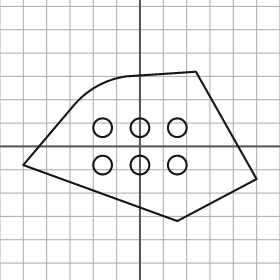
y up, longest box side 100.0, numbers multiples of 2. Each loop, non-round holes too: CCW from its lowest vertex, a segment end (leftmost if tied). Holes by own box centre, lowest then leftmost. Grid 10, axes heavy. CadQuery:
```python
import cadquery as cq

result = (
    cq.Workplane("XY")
    .moveTo(16.0, -32.0)
    .lineTo(50.0, -14.0)
    .lineTo(24.0, 32.0)
    .lineTo(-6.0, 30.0)
    .threePointArc((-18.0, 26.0), (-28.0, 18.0))
    .lineTo(-50.0, -8.0)
    .close()
    .moveTo(-16.0, -8.0)
    .circle(4.0)
    .moveTo(0.0, -8.0)
    .circle(4.0)
    .moveTo(16.0, -8.0)
    .circle(4.0)
    .moveTo(-16.0, 8.0)
    .circle(4.0)
    .moveTo(0.0, 8.0)
    .circle(4.0)
    .moveTo(16.0, 8.0)
    .circle(4.0)
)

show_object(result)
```